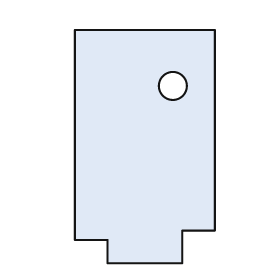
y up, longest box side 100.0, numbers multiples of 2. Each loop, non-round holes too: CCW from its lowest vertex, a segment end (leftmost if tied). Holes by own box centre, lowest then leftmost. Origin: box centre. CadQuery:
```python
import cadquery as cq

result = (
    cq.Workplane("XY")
    .moveTo(-16.0, -50.0)
    .lineTo(16.0, -50.0)
    .lineTo(16.0, -36.0)
    .lineTo(30.0, -36.0)
    .lineTo(30.0, 50.0)
    .lineTo(-30.0, 50.0)
    .lineTo(-30.0, -40.0)
    .lineTo(-16.0, -40.0)
    .close()
    .moveTo(12.0, 26.0)
    .circle(6.0)
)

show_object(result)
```